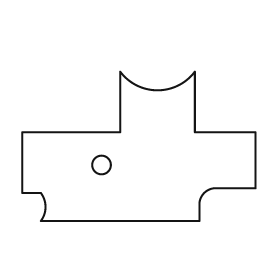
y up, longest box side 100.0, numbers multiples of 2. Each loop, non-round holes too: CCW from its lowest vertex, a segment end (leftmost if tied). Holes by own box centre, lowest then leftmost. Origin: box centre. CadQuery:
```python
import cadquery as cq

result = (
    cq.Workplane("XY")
    .moveTo(-42.0, -32.0)
    .lineTo(26.0, -32.0)
    .lineTo(26.0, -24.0)
    .threePointArc((28.0, -20.0), (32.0, -18.0))
    .lineTo(50.0, -18.0)
    .lineTo(50.0, 6.0)
    .lineTo(24.0, 6.0)
    .lineTo(24.0, 32.0)
    .threePointArc((8.0, 24.0), (-8.0, 32.0))
    .lineTo(-8.0, 6.0)
    .lineTo(-50.0, 6.0)
    .lineTo(-50.0, -20.0)
    .lineTo(-42.0, -20.0)
    .threePointArc((-40.0, -26.0), (-42.0, -32.0))
    .close()
    .moveTo(-16.0, -8.0)
    .circle(4.0)
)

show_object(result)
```